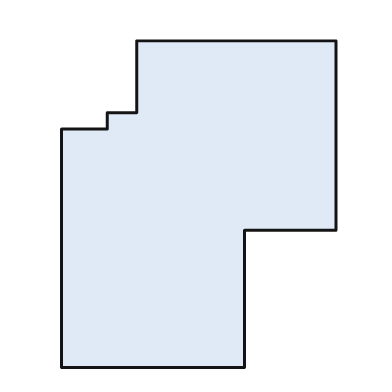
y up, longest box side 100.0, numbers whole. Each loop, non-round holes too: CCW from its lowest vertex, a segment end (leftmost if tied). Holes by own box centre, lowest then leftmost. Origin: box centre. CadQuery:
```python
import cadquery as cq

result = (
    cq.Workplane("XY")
    .moveTo(-42.0, -50.0)
    .lineTo(14.0, -50.0)
    .lineTo(14.0, -8.0)
    .lineTo(42.0, -8.0)
    .lineTo(42.0, 50.0)
    .lineTo(-19.0, 50.0)
    .lineTo(-19.0, 28.0)
    .lineTo(-28.0, 28.0)
    .lineTo(-28.0, 23.0)
    .lineTo(-42.0, 23.0)
    .close()
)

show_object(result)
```